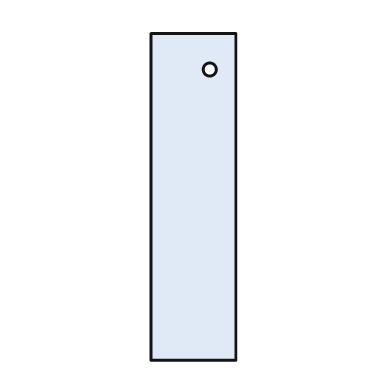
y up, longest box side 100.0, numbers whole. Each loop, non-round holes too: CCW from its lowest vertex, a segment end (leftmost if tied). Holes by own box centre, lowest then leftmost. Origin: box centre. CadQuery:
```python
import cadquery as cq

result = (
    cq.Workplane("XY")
    .moveTo(-13.0, -50.0)
    .lineTo(13.0, -50.0)
    .lineTo(13.0, 50.0)
    .lineTo(-13.0, 50.0)
    .close()
    .moveTo(5.0, 39.0)
    .circle(2.0)
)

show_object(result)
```